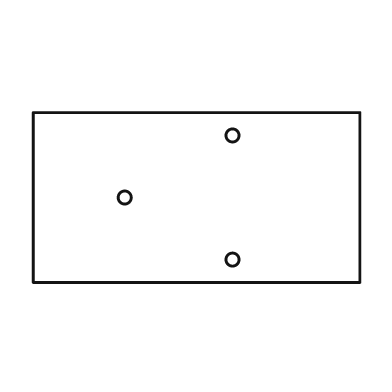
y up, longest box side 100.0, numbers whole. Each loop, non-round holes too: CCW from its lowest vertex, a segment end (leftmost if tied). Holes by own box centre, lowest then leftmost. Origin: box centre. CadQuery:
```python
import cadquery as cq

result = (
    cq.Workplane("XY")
    .moveTo(-50.0, -26.0)
    .lineTo(50.0, -26.0)
    .lineTo(50.0, 26.0)
    .lineTo(-50.0, 26.0)
    .close()
    .moveTo(11.0, -19.0)
    .circle(2.0)
    .moveTo(-22.0, 0.0)
    .circle(2.0)
    .moveTo(11.0, 19.0)
    .circle(2.0)
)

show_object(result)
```